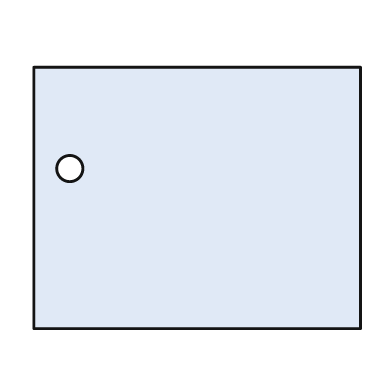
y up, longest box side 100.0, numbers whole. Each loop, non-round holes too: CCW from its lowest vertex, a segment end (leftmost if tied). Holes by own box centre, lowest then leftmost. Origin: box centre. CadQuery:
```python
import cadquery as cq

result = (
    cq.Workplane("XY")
    .moveTo(-50.0, -40.0)
    .lineTo(50.0, -40.0)
    .lineTo(50.0, 40.0)
    .lineTo(-50.0, 40.0)
    .close()
    .moveTo(-39.0, 9.0)
    .circle(4.0)
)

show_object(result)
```